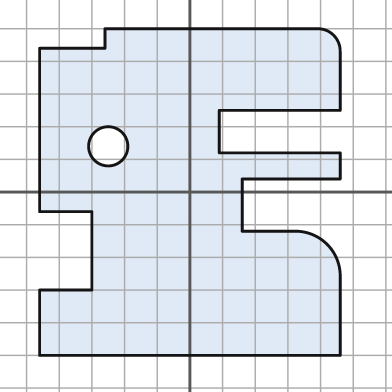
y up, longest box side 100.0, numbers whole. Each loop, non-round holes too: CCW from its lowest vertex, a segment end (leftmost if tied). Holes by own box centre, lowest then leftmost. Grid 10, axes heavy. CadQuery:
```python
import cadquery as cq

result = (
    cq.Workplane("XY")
    .moveTo(-46.0, -50.0)
    .lineTo(46.0, -50.0)
    .lineTo(46.0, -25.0)
    .threePointArc((42.0, -16.0), (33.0, -12.0))
    .lineTo(16.0, -12.0)
    .lineTo(16.0, 4.0)
    .lineTo(46.0, 4.0)
    .lineTo(46.0, 12.0)
    .lineTo(9.0, 12.0)
    .lineTo(9.0, 25.0)
    .lineTo(46.0, 25.0)
    .lineTo(46.0, 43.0)
    .threePointArc((44.0, 48.0), (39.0, 50.0))
    .lineTo(-26.0, 50.0)
    .lineTo(-26.0, 44.0)
    .lineTo(-46.0, 44.0)
    .lineTo(-46.0, -6.0)
    .lineTo(-30.0, -6.0)
    .lineTo(-30.0, -30.0)
    .lineTo(-46.0, -30.0)
    .close()
    .moveTo(-25.0, 14.0)
    .circle(6.0)
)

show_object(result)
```